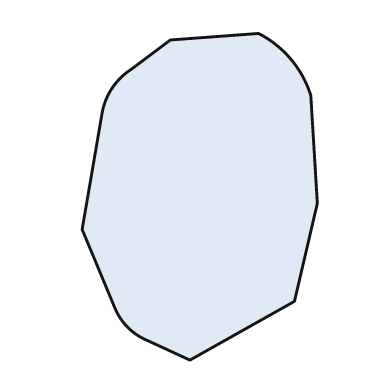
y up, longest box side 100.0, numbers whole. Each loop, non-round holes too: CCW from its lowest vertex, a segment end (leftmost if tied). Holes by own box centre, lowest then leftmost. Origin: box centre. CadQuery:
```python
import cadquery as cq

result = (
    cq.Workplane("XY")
    .moveTo(-3.0, -50.0)
    .lineTo(29.0, -32.0)
    .lineTo(36.0, -2.0)
    .lineTo(34.0, 31.0)
    .threePointArc((28.0, 42.0), (18.0, 50.0))
    .lineTo(-9.0, 48.0)
    .lineTo(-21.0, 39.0)
    .threePointArc((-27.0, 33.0), (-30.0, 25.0))
    .lineTo(-36.0, -10.0)
    .lineTo(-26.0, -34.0)
    .threePointArc((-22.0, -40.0), (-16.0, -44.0))
    .close()
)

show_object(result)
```